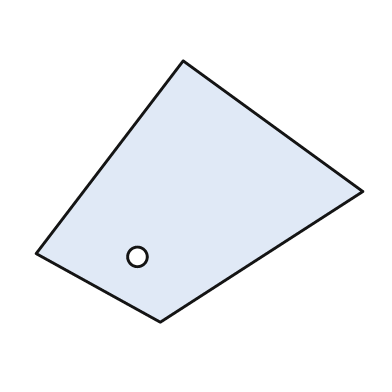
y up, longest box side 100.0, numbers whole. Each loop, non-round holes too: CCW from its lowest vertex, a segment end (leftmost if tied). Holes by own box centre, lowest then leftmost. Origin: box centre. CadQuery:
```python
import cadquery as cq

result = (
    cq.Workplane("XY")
    .moveTo(-12.0, -40.0)
    .lineTo(50.0, 0.0)
    .lineTo(-5.0, 40.0)
    .lineTo(-50.0, -19.0)
    .close()
    .moveTo(-19.0, -20.0)
    .circle(3.0)
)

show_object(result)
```